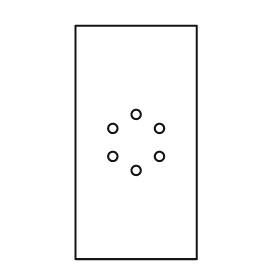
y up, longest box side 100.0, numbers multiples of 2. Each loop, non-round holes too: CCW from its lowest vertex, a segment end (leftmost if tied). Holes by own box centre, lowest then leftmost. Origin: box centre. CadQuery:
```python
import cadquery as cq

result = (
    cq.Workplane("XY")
    .moveTo(-26.0, -50.0)
    .lineTo(26.0, -50.0)
    .lineTo(26.0, 50.0)
    .lineTo(-26.0, 50.0)
    .close()
    .moveTo(0.0, -12.0)
    .circle(2.0)
    .moveTo(-10.0, -6.0)
    .circle(2.0)
    .moveTo(10.0, -6.0)
    .circle(2.0)
    .moveTo(-10.0, 6.0)
    .circle(2.0)
    .moveTo(10.0, 6.0)
    .circle(2.0)
    .moveTo(0.0, 12.0)
    .circle(2.0)
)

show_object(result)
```